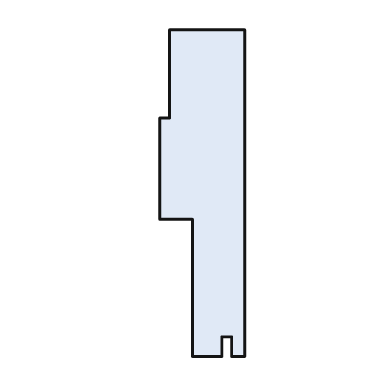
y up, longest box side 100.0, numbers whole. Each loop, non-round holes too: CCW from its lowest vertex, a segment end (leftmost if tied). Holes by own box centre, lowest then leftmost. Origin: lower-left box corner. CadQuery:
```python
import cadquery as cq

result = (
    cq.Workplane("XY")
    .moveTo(10.0, 0.0)
    .lineTo(19.0, 0.0)
    .lineTo(19.0, 6.0)
    .lineTo(22.0, 6.0)
    .lineTo(22.0, 0.0)
    .lineTo(26.0, 0.0)
    .lineTo(26.0, 100.0)
    .lineTo(3.0, 100.0)
    .lineTo(3.0, 73.0)
    .lineTo(0.0, 73.0)
    .lineTo(0.0, 42.0)
    .lineTo(10.0, 42.0)
    .close()
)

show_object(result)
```